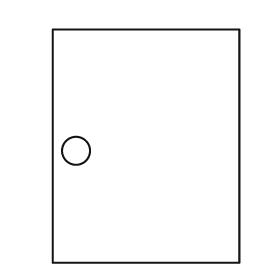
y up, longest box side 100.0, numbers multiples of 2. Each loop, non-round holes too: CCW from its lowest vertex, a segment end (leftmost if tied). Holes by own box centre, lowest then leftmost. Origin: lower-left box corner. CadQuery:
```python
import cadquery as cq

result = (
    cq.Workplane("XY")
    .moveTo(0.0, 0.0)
    .lineTo(80.0, 0.0)
    .lineTo(80.0, 100.0)
    .lineTo(0.0, 100.0)
    .close()
    .moveTo(10.0, 48.0)
    .circle(6.0)
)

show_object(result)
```